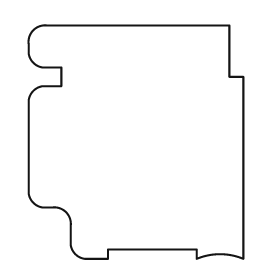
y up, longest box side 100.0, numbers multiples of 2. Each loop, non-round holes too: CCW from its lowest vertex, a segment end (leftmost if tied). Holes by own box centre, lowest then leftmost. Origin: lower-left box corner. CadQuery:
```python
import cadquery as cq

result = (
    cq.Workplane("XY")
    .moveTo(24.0, 0.0)
    .lineTo(34.0, 0.0)
    .lineTo(34.0, 4.0)
    .lineTo(72.0, 4.0)
    .lineTo(72.0, 0.0)
    .threePointArc((82.0, 2.0), (92.0, 0.0))
    .lineTo(92.0, 78.0)
    .lineTo(86.0, 78.0)
    .lineTo(86.0, 100.0)
    .lineTo(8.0, 100.0)
    .threePointArc((2.0, 98.0), (0.0, 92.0))
    .lineTo(0.0, 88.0)
    .threePointArc((2.0, 84.0), (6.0, 82.0))
    .lineTo(14.0, 82.0)
    .lineTo(14.0, 74.0)
    .lineTo(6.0, 74.0)
    .threePointArc((2.0, 72.0), (0.0, 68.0))
    .lineTo(0.0, 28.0)
    .threePointArc((2.0, 24.0), (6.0, 22.0))
    .lineTo(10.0, 22.0)
    .threePointArc((16.0, 20.0), (18.0, 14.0))
    .lineTo(18.0, 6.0)
    .threePointArc((20.0, 2.0), (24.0, 0.0))
    .close()
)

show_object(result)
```